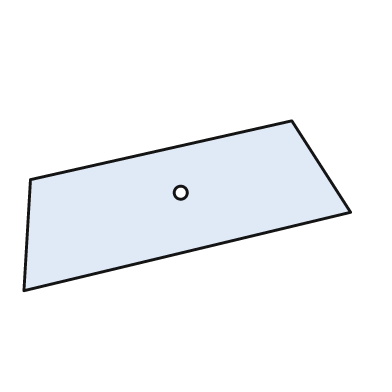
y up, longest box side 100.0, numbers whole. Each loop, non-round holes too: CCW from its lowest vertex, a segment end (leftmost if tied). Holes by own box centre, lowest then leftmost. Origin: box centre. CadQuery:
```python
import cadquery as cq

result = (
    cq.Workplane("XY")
    .moveTo(-50.0, -26.0)
    .lineTo(50.0, -2.0)
    .lineTo(32.0, 26.0)
    .lineTo(-48.0, 8.0)
    .close()
    .moveTo(-2.0, 4.0)
    .circle(2.0)
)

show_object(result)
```